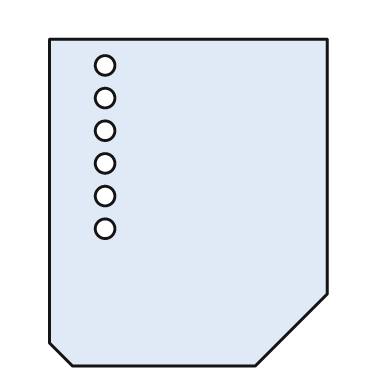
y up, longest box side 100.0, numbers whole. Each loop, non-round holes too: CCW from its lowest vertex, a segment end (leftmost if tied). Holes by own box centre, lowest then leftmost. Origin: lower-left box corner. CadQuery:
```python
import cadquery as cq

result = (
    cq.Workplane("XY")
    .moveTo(7.0, 0.0)
    .lineTo(63.0, 0.0)
    .lineTo(85.0, 22.0)
    .lineTo(85.0, 100.0)
    .lineTo(0.0, 100.0)
    .lineTo(0.0, 7.0)
    .close()
    .moveTo(17.0, 42.0)
    .circle(3.0)
    .moveTo(17.0, 52.0)
    .circle(3.0)
    .moveTo(17.0, 62.0)
    .circle(3.0)
    .moveTo(17.0, 72.0)
    .circle(3.0)
    .moveTo(17.0, 82.0)
    .circle(3.0)
    .moveTo(17.0, 92.0)
    .circle(3.0)
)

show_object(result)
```